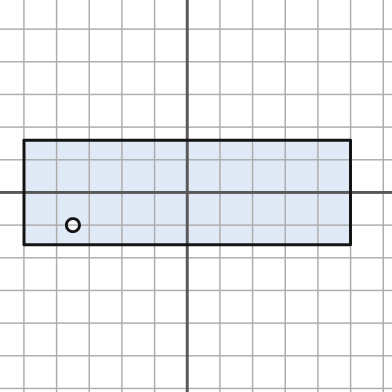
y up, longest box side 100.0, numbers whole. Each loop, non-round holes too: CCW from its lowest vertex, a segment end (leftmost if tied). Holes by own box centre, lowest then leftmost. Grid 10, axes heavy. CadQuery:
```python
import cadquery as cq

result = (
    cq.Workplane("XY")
    .moveTo(-50.0, -16.0)
    .lineTo(50.0, -16.0)
    .lineTo(50.0, 16.0)
    .lineTo(-50.0, 16.0)
    .close()
    .moveTo(-35.0, -10.0)
    .circle(2.0)
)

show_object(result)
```